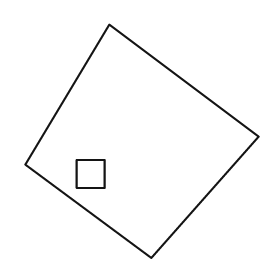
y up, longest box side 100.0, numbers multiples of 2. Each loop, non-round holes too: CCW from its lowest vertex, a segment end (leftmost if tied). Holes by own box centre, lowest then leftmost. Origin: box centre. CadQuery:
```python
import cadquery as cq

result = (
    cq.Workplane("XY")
    .moveTo(4.0, -50.0)
    .lineTo(50.0, 2.0)
    .lineTo(-14.0, 50.0)
    .lineTo(-50.0, -10.0)
    .close()
    .moveTo(-28.0, -20.0)
    .lineTo(-16.0, -20.0)
    .lineTo(-16.0, -8.0)
    .lineTo(-28.0, -8.0)
    .close()
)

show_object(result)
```